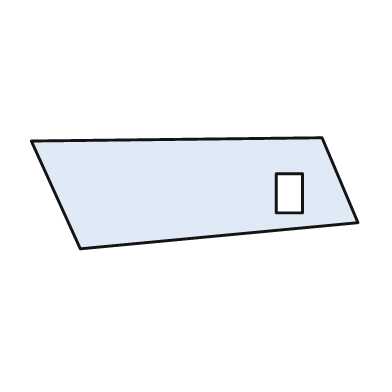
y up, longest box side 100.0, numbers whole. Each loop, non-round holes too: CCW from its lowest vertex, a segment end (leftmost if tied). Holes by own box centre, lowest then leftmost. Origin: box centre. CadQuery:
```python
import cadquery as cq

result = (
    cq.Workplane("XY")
    .moveTo(-35.0, -17.0)
    .lineTo(50.0, -9.0)
    .lineTo(39.0, 17.0)
    .lineTo(-50.0, 16.0)
    .close()
    .moveTo(25.0, -6.0)
    .lineTo(33.0, -6.0)
    .lineTo(33.0, 6.0)
    .lineTo(25.0, 6.0)
    .close()
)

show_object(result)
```